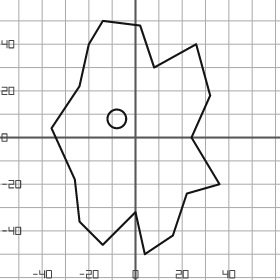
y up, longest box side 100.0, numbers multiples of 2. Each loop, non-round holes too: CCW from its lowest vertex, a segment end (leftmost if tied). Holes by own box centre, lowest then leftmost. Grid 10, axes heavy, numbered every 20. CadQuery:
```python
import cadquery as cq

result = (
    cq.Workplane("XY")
    .moveTo(4.0, -50.0)
    .lineTo(16.0, -42.0)
    .lineTo(22.0, -24.0)
    .lineTo(36.0, -20.0)
    .lineTo(24.0, 0.0)
    .lineTo(32.0, 18.0)
    .lineTo(26.0, 40.0)
    .lineTo(8.0, 30.0)
    .lineTo(2.0, 48.0)
    .lineTo(-14.0, 50.0)
    .lineTo(-20.0, 40.0)
    .lineTo(-24.0, 22.0)
    .lineTo(-36.0, 4.0)
    .lineTo(-26.0, -18.0)
    .lineTo(-24.0, -36.0)
    .lineTo(-14.0, -46.0)
    .lineTo(0.0, -32.0)
    .close()
    .moveTo(-8.0, 8.0)
    .circle(4.0)
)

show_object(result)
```